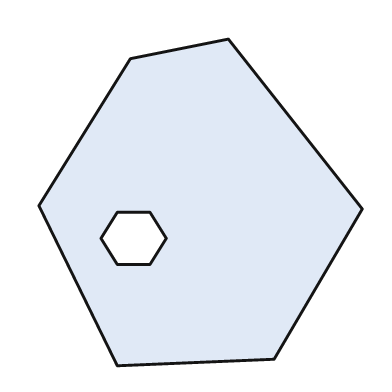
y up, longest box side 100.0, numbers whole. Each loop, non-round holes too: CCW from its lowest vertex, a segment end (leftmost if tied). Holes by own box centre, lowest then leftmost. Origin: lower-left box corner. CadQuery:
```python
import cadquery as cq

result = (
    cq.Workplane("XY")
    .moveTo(24.0, 0.0)
    .lineTo(72.0, 2.0)
    .lineTo(99.0, 48.0)
    .lineTo(58.0, 100.0)
    .lineTo(28.0, 94.0)
    .lineTo(0.0, 49.0)
    .close()
    .moveTo(24.0, 31.0)
    .lineTo(34.0, 31.0)
    .lineTo(39.0, 39.0)
    .lineTo(34.0, 47.0)
    .lineTo(24.0, 47.0)
    .lineTo(19.0, 39.0)
    .close()
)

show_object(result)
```